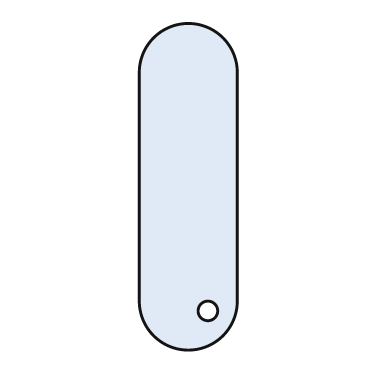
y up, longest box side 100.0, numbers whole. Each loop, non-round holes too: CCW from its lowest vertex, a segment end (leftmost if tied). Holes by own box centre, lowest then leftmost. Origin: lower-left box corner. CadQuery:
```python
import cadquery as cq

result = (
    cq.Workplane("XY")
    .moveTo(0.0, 15.0)
    .threePointArc((15.0, 0.0), (30.0, 15.0))
    .lineTo(30.0, 85.0)
    .threePointArc((15.0, 100.0), (0.0, 85.0))
    .close()
    .moveTo(21.0, 12.0)
    .circle(3.0)
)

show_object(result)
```